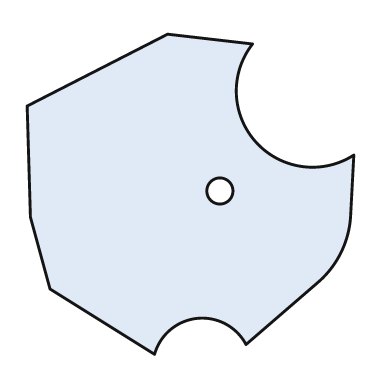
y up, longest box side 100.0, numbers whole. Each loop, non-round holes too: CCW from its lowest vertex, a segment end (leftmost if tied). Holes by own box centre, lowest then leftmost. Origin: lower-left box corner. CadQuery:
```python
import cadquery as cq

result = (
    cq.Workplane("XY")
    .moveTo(39.0, 0.0)
    .threePointArc((52.0, 11.0), (67.0, 3.0))
    .lineTo(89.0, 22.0)
    .threePointArc((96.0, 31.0), (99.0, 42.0))
    .lineTo(100.0, 61.0)
    .threePointArc((70.0, 65.0), (69.0, 95.0))
    .lineTo(43.0, 98.0)
    .lineTo(0.0, 76.0)
    .lineTo(1.0, 42.0)
    .lineTo(7.0, 20.0)
    .close()
    .moveTo(59.0, 50.0)
    .circle(4.0)
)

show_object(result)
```